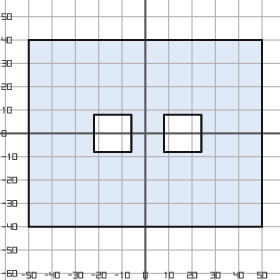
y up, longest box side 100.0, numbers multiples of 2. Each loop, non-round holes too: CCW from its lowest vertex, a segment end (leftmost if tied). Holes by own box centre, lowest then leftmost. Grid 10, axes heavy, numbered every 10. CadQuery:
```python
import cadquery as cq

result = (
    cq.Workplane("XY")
    .moveTo(-50.0, -40.0)
    .lineTo(50.0, -40.0)
    .lineTo(50.0, 40.0)
    .lineTo(-50.0, 40.0)
    .close()
    .moveTo(-22.0, -8.0)
    .lineTo(-6.0, -8.0)
    .lineTo(-6.0, 8.0)
    .lineTo(-22.0, 8.0)
    .close()
    .moveTo(8.0, -8.0)
    .lineTo(24.0, -8.0)
    .lineTo(24.0, 8.0)
    .lineTo(8.0, 8.0)
    .close()
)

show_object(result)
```